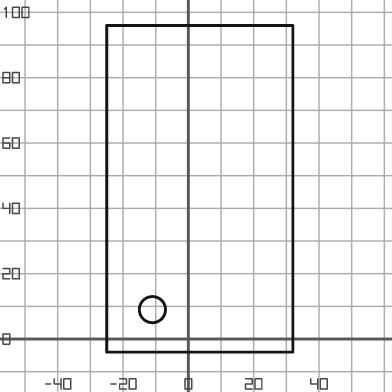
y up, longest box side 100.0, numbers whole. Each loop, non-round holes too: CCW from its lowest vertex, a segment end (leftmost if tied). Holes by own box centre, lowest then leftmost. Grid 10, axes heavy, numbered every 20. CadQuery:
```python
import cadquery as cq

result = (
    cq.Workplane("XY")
    .moveTo(-25.0, -4.0)
    .lineTo(32.0, -4.0)
    .lineTo(32.0, 96.0)
    .lineTo(-25.0, 96.0)
    .close()
    .moveTo(-11.0, 9.0)
    .circle(4.0)
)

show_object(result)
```